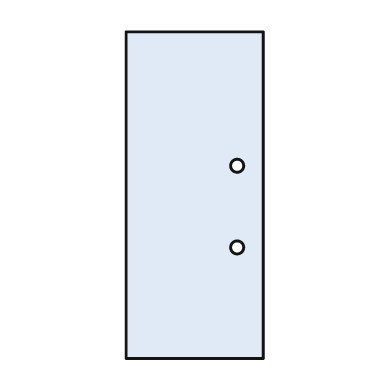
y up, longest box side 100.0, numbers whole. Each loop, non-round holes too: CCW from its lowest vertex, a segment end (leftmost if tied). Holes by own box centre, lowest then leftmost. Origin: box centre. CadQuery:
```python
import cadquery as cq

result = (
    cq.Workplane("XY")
    .moveTo(-21.0, -50.0)
    .lineTo(21.0, -50.0)
    .lineTo(21.0, 50.0)
    .lineTo(-21.0, 50.0)
    .close()
    .moveTo(13.0, -16.0)
    .circle(2.0)
    .moveTo(13.0, 9.0)
    .circle(2.0)
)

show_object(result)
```